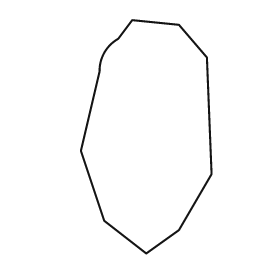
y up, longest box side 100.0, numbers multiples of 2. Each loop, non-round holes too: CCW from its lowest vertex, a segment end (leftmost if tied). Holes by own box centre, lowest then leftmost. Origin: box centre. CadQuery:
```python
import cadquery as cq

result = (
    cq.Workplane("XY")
    .moveTo(0.0, -50.0)
    .lineTo(14.0, -40.0)
    .lineTo(28.0, -16.0)
    .lineTo(26.0, 34.0)
    .lineTo(14.0, 48.0)
    .lineTo(-6.0, 50.0)
    .lineTo(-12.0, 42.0)
    .threePointArc((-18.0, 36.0), (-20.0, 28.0))
    .lineTo(-28.0, -6.0)
    .lineTo(-18.0, -36.0)
    .close()
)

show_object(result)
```